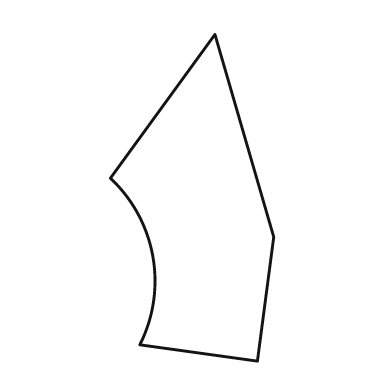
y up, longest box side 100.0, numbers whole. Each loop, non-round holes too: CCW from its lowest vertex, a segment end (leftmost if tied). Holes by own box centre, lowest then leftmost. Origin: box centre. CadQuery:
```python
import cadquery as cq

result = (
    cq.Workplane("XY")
    .moveTo(20.0, -50.0)
    .lineTo(25.0, -12.0)
    .lineTo(7.0, 50.0)
    .lineTo(-25.0, 6.0)
    .threePointArc((-12.0, -18.0), (-16.0, -45.0))
    .close()
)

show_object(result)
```